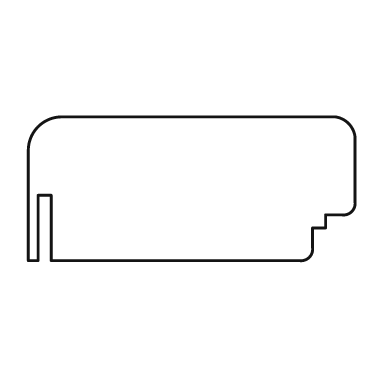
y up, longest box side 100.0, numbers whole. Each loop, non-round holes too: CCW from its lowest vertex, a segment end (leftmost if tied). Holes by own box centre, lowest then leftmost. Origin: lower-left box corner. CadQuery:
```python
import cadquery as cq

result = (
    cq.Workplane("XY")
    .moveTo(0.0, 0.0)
    .lineTo(3.0, 0.0)
    .lineTo(3.0, 20.0)
    .lineTo(7.0, 20.0)
    .lineTo(7.0, 0.0)
    .lineTo(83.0, 0.0)
    .threePointArc((86.0, 1.0), (87.0, 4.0))
    .lineTo(87.0, 10.0)
    .lineTo(91.0, 10.0)
    .lineTo(91.0, 14.0)
    .lineTo(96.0, 14.0)
    .threePointArc((99.0, 15.0), (100.0, 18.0))
    .lineTo(100.0, 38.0)
    .threePointArc((98.0, 42.0), (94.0, 44.0))
    .lineTo(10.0, 44.0)
    .threePointArc((3.0, 41.0), (0.0, 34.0))
    .close()
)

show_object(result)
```